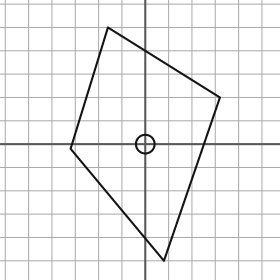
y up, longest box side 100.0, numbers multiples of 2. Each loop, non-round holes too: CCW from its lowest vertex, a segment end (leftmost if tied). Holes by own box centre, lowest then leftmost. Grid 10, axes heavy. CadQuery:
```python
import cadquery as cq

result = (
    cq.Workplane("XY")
    .moveTo(8.0, -50.0)
    .lineTo(32.0, 20.0)
    .lineTo(-16.0, 50.0)
    .lineTo(-32.0, -2.0)
    .close()
    .moveTo(0.0, 0.0)
    .circle(4.0)
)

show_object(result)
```